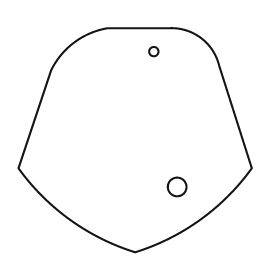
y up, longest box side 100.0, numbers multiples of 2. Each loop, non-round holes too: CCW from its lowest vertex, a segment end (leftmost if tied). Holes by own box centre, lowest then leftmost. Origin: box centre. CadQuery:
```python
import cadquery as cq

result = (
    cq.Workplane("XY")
    .moveTo(0.0, -48.0)
    .threePointArc((28.0, -34.0), (50.0, -12.0))
    .lineTo(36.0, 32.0)
    .threePointArc((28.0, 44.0), (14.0, 48.0))
    .lineTo(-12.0, 48.0)
    .threePointArc((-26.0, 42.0), (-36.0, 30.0))
    .lineTo(-50.0, -12.0)
    .threePointArc((-28.0, -34.0), (0.0, -48.0))
    .close()
    .moveTo(18.0, -20.0)
    .circle(4.0)
    .moveTo(8.0, 38.0)
    .circle(2.0)
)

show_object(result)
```